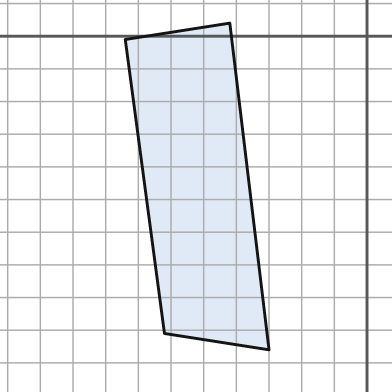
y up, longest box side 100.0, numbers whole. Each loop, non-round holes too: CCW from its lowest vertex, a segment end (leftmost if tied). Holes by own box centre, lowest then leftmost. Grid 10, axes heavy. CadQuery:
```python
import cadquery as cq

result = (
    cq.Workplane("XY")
    .moveTo(-30.0, -96.0)
    .lineTo(-42.0, 4.0)
    .lineTo(-74.0, -1.0)
    .lineTo(-62.0, -91.0)
    .close()
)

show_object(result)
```